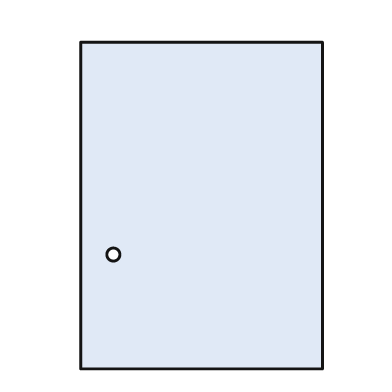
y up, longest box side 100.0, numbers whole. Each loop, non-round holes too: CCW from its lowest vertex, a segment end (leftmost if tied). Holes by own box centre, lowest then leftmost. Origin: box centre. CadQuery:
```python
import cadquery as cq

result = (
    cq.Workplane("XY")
    .moveTo(-37.0, -50.0)
    .lineTo(37.0, -50.0)
    .lineTo(37.0, 50.0)
    .lineTo(-37.0, 50.0)
    .close()
    .moveTo(-27.0, -15.0)
    .circle(2.0)
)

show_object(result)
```